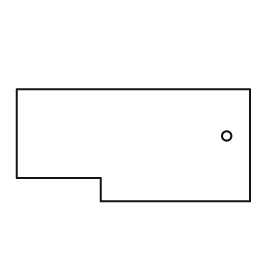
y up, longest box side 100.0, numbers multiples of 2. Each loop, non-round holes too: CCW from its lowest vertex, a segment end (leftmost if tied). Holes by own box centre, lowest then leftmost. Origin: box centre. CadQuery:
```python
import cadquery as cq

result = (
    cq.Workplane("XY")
    .moveTo(-14.0, -24.0)
    .lineTo(50.0, -24.0)
    .lineTo(50.0, 24.0)
    .lineTo(-50.0, 24.0)
    .lineTo(-50.0, -14.0)
    .lineTo(-14.0, -14.0)
    .close()
    .moveTo(40.0, 4.0)
    .circle(2.0)
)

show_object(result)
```